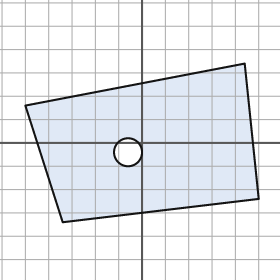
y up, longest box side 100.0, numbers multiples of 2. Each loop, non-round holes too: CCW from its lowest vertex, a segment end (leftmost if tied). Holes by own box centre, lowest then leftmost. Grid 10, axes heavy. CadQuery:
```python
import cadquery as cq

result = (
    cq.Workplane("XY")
    .moveTo(-34.0, -34.0)
    .lineTo(50.0, -24.0)
    .lineTo(44.0, 34.0)
    .lineTo(-50.0, 16.0)
    .close()
    .moveTo(-6.0, -4.0)
    .circle(6.0)
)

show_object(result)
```